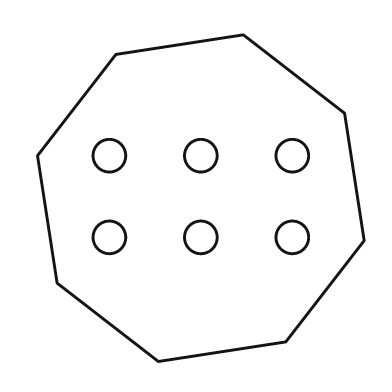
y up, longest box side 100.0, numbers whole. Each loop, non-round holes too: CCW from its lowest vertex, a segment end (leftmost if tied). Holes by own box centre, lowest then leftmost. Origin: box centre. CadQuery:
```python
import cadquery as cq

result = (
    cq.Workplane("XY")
    .moveTo(-13.0, -50.0)
    .lineTo(26.0, -44.0)
    .lineTo(50.0, -13.0)
    .lineTo(44.0, 26.0)
    .lineTo(13.0, 50.0)
    .lineTo(-26.0, 44.0)
    .lineTo(-50.0, 13.0)
    .lineTo(-44.0, -26.0)
    .close()
    .moveTo(-28.0, -12.0)
    .circle(5.0)
    .moveTo(0.0, -12.0)
    .circle(5.0)
    .moveTo(28.0, -12.0)
    .circle(5.0)
    .moveTo(-28.0, 13.0)
    .circle(5.0)
    .moveTo(0.0, 13.0)
    .circle(5.0)
    .moveTo(28.0, 13.0)
    .circle(5.0)
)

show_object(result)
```